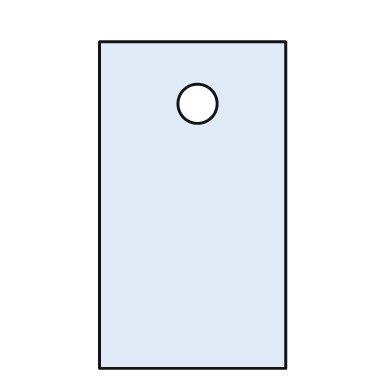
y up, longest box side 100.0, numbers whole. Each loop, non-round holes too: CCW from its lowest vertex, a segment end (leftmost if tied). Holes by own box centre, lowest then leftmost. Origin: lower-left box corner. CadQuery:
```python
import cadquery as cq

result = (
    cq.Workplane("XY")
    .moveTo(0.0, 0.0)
    .lineTo(57.0, 0.0)
    .lineTo(57.0, 100.0)
    .lineTo(0.0, 100.0)
    .close()
    .moveTo(30.0, 81.0)
    .circle(6.0)
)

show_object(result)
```